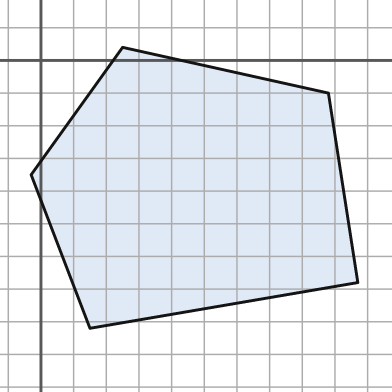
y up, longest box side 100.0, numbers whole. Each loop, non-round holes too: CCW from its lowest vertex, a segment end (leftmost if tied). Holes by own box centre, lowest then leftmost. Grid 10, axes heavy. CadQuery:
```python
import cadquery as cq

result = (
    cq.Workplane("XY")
    .moveTo(15.0, -82.0)
    .lineTo(97.0, -68.0)
    .lineTo(88.0, -10.0)
    .lineTo(25.0, 4.0)
    .lineTo(-3.0, -35.0)
    .close()
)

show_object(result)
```